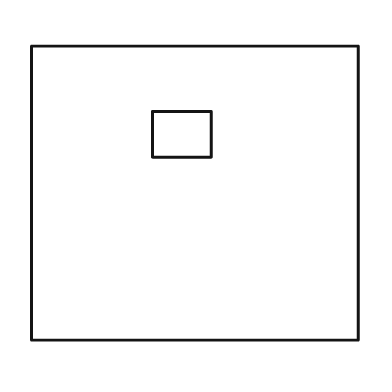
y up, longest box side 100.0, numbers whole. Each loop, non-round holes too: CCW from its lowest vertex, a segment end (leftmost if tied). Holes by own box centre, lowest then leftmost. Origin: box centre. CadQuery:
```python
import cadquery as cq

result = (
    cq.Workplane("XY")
    .moveTo(-50.0, -45.0)
    .lineTo(50.0, -45.0)
    .lineTo(50.0, 45.0)
    .lineTo(-50.0, 45.0)
    .close()
    .moveTo(-13.0, 11.0)
    .lineTo(5.0, 11.0)
    .lineTo(5.0, 25.0)
    .lineTo(-13.0, 25.0)
    .close()
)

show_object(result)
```